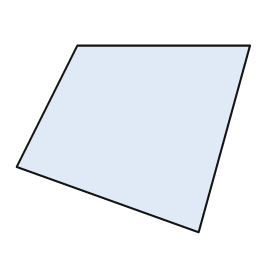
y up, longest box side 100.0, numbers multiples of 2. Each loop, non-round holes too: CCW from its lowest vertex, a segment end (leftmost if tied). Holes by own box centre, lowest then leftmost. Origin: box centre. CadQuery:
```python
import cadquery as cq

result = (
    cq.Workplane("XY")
    .moveTo(28.0, -40.0)
    .lineTo(50.0, 40.0)
    .lineTo(-24.0, 40.0)
    .lineTo(-50.0, -12.0)
    .close()
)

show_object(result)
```